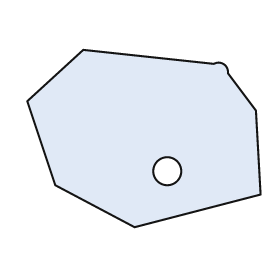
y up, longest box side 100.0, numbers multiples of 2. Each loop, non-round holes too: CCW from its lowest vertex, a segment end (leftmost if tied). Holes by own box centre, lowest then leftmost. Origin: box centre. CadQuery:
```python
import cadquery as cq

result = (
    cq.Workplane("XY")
    .moveTo(-4.0, -38.0)
    .lineTo(50.0, -24.0)
    .lineTo(48.0, 12.0)
    .lineTo(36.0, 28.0)
    .threePointArc((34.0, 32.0), (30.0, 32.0))
    .lineTo(-26.0, 38.0)
    .lineTo(-50.0, 16.0)
    .lineTo(-38.0, -20.0)
    .close()
    .moveTo(10.0, -14.0)
    .circle(6.0)
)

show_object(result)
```